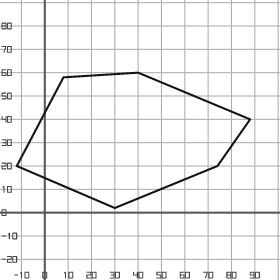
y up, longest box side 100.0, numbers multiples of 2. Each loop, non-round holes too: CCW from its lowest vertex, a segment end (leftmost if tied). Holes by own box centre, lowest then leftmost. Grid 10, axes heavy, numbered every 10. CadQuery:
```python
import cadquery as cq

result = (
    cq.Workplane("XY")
    .moveTo(30.0, 2.0)
    .lineTo(74.0, 20.0)
    .lineTo(88.0, 40.0)
    .lineTo(40.0, 60.0)
    .lineTo(8.0, 58.0)
    .lineTo(-12.0, 20.0)
    .close()
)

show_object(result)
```